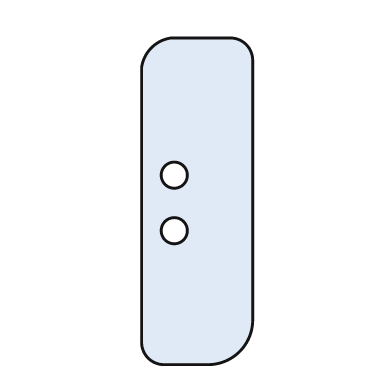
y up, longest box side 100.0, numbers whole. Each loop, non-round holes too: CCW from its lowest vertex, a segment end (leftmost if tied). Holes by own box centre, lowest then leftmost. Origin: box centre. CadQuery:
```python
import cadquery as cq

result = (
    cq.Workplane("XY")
    .moveTo(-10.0, -50.0)
    .lineTo(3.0, -50.0)
    .threePointArc((13.0, -46.0), (17.0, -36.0))
    .lineTo(17.0, 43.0)
    .threePointArc((15.0, 48.0), (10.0, 50.0))
    .lineTo(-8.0, 50.0)
    .threePointArc((-14.0, 47.0), (-17.0, 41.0))
    .lineTo(-17.0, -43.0)
    .threePointArc((-15.0, -48.0), (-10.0, -50.0))
    .close()
    .moveTo(-7.0, -9.0)
    .circle(4.0)
    .moveTo(-7.0, 8.0)
    .circle(4.0)
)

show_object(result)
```